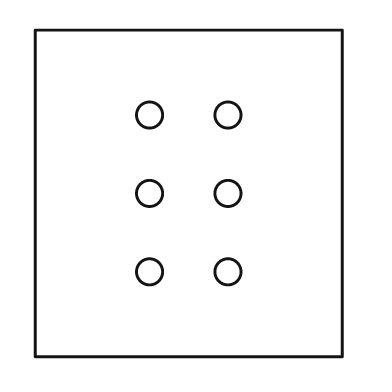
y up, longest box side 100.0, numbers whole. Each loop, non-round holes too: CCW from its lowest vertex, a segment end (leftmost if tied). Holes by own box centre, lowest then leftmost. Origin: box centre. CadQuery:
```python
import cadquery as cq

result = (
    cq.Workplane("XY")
    .moveTo(-47.0, -50.0)
    .lineTo(47.0, -50.0)
    .lineTo(47.0, 50.0)
    .lineTo(-47.0, 50.0)
    .close()
    .moveTo(-12.0, -24.0)
    .circle(4.0)
    .moveTo(12.0, -24.0)
    .circle(4.0)
    .moveTo(-12.0, 0.0)
    .circle(4.0)
    .moveTo(12.0, 0.0)
    .circle(4.0)
    .moveTo(-12.0, 24.0)
    .circle(4.0)
    .moveTo(12.0, 24.0)
    .circle(4.0)
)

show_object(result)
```